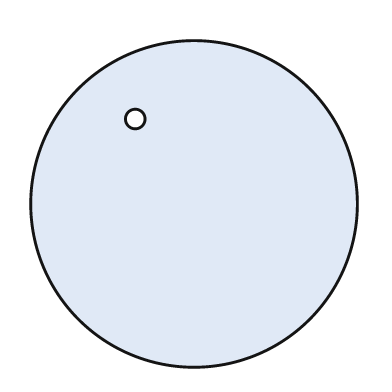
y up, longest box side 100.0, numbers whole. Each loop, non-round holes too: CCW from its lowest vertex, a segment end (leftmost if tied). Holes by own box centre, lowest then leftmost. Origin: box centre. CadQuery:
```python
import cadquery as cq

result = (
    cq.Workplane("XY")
    .moveTo(0.0, 0.0)
    .circle(50.0)
    .moveTo(-18.0, 26.0)
    .circle(3.0)
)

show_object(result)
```